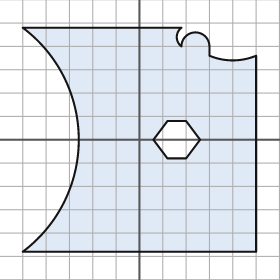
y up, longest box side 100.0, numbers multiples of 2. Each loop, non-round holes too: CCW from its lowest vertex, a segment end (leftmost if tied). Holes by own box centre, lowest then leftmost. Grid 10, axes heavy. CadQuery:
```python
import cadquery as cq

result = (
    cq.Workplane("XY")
    .moveTo(-50.0, -48.0)
    .lineTo(50.0, -48.0)
    .lineTo(50.0, 36.0)
    .threePointArc((40.0, 34.0), (30.0, 36.0))
    .lineTo(30.0, 40.0)
    .threePointArc((24.0, 46.0), (18.0, 40.0))
    .threePointArc((16.0, 44.0), (18.0, 48.0))
    .lineTo(-50.0, 48.0)
    .threePointArc((-26.0, 0.0), (-50.0, -48.0))
    .close()
    .moveTo(12.0, -8.0)
    .lineTo(20.0, -8.0)
    .lineTo(26.0, 0.0)
    .lineTo(20.0, 8.0)
    .lineTo(12.0, 8.0)
    .lineTo(6.0, 0.0)
    .close()
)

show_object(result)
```